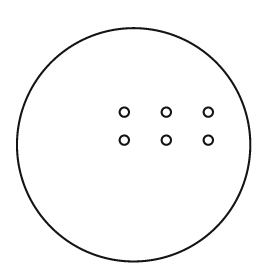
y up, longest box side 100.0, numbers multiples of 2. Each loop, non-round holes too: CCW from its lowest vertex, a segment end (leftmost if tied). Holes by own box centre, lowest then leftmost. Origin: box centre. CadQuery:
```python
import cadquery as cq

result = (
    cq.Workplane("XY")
    .moveTo(0.0, 0.0)
    .circle(50.0)
    .moveTo(-4.0, 2.0)
    .circle(2.0)
    .moveTo(14.0, 2.0)
    .circle(2.0)
    .moveTo(32.0, 2.0)
    .circle(2.0)
    .moveTo(-4.0, 14.0)
    .circle(2.0)
    .moveTo(14.0, 14.0)
    .circle(2.0)
    .moveTo(32.0, 14.0)
    .circle(2.0)
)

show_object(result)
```